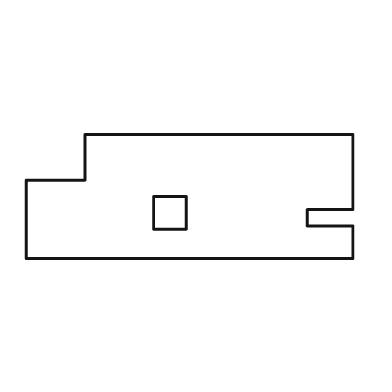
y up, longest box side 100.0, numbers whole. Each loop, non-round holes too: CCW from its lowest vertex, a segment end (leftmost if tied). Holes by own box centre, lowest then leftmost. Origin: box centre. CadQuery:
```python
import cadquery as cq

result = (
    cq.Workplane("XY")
    .moveTo(-50.0, -19.0)
    .lineTo(50.0, -19.0)
    .lineTo(50.0, -9.0)
    .lineTo(36.0, -9.0)
    .lineTo(36.0, -4.0)
    .lineTo(50.0, -4.0)
    .lineTo(50.0, 19.0)
    .lineTo(-32.0, 19.0)
    .lineTo(-32.0, 5.0)
    .lineTo(-50.0, 5.0)
    .close()
    .moveTo(-11.0, -10.0)
    .lineTo(-1.0, -10.0)
    .lineTo(-1.0, 0.0)
    .lineTo(-11.0, 0.0)
    .close()
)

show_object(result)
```